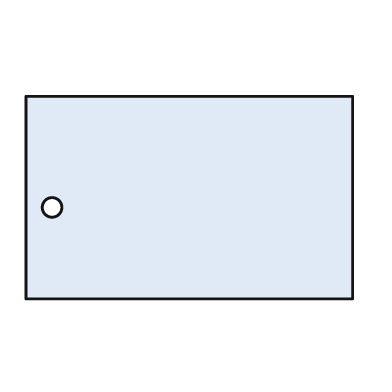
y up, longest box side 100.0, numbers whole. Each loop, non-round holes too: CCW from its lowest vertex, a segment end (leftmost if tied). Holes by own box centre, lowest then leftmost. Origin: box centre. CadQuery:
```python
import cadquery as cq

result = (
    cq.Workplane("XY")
    .moveTo(-50.0, -31.0)
    .lineTo(50.0, -31.0)
    .lineTo(50.0, 31.0)
    .lineTo(-50.0, 31.0)
    .close()
    .moveTo(-42.0, -3.0)
    .circle(3.0)
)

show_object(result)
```